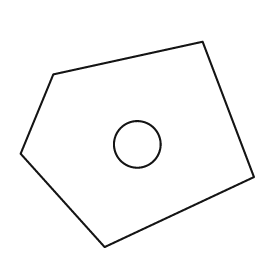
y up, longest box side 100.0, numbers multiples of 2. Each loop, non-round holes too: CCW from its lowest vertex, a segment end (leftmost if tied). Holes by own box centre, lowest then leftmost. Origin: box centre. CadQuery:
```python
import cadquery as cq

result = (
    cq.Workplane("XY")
    .moveTo(-14.0, -44.0)
    .lineTo(50.0, -14.0)
    .lineTo(28.0, 44.0)
    .lineTo(-36.0, 30.0)
    .lineTo(-50.0, -4.0)
    .close()
    .moveTo(0.0, 0.0)
    .circle(10.0)
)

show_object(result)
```